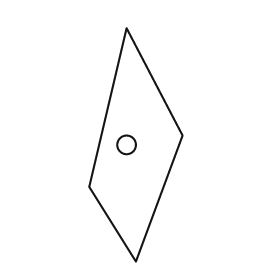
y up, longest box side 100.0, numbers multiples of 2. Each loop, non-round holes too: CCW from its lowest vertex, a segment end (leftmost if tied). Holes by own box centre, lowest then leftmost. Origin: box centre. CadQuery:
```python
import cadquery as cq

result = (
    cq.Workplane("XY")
    .moveTo(0.0, -50.0)
    .lineTo(20.0, 4.0)
    .lineTo(-4.0, 50.0)
    .lineTo(-20.0, -18.0)
    .close()
    .moveTo(-4.0, 0.0)
    .circle(4.0)
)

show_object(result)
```